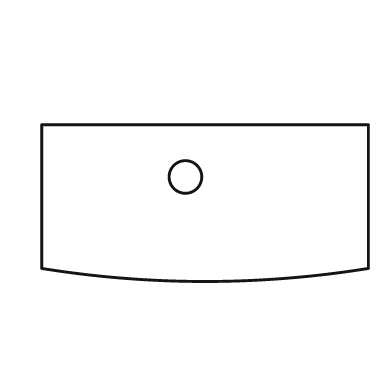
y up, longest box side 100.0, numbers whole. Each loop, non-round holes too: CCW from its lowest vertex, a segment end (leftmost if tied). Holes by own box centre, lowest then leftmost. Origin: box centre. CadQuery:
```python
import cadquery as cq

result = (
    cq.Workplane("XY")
    .moveTo(-50.0, -20.0)
    .threePointArc((0.0, -24.0), (50.0, -20.0))
    .lineTo(50.0, 24.0)
    .lineTo(-50.0, 24.0)
    .close()
    .moveTo(-6.0, 8.0)
    .circle(5.0)
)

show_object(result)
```